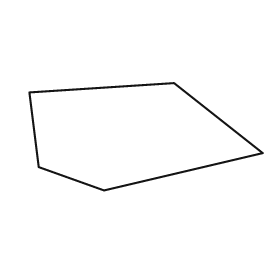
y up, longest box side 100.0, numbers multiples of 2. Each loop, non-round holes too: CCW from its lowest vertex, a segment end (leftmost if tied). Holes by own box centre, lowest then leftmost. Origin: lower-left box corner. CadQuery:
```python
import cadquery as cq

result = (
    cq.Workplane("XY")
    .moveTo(32.0, 0.0)
    .lineTo(100.0, 16.0)
    .lineTo(62.0, 46.0)
    .lineTo(0.0, 42.0)
    .lineTo(4.0, 10.0)
    .close()
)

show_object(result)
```